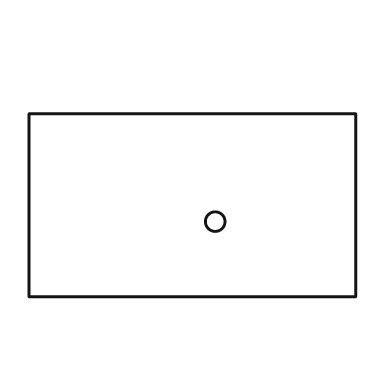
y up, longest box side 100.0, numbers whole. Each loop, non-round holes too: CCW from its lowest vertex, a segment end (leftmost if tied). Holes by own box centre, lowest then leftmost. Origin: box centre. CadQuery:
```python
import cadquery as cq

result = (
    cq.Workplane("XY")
    .moveTo(-50.0, -28.0)
    .lineTo(50.0, -28.0)
    .lineTo(50.0, 28.0)
    .lineTo(-50.0, 28.0)
    .close()
    .moveTo(7.0, -5.0)
    .circle(3.0)
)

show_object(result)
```